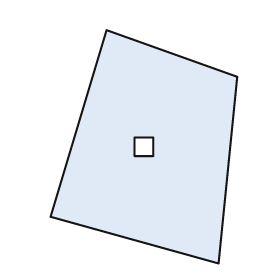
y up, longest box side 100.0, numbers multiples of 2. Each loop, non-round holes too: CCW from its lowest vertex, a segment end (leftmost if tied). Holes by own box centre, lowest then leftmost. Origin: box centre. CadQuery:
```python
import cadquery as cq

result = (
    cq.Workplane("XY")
    .moveTo(32.0, -50.0)
    .lineTo(40.0, 30.0)
    .lineTo(-16.0, 50.0)
    .lineTo(-40.0, -30.0)
    .close()
    .moveTo(-4.0, -4.0)
    .lineTo(4.0, -4.0)
    .lineTo(4.0, 4.0)
    .lineTo(-4.0, 4.0)
    .close()
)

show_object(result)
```